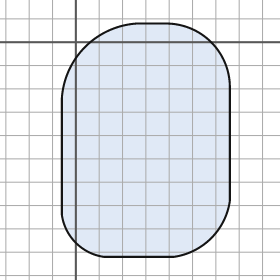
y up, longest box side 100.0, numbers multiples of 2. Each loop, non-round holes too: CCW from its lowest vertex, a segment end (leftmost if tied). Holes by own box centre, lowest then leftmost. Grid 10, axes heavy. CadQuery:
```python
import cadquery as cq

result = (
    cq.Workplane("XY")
    .moveTo(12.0, -92.0)
    .lineTo(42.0, -92.0)
    .threePointArc((58.0, -84.0), (66.0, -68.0))
    .lineTo(66.0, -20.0)
    .threePointArc((58.0, 0.0), (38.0, 8.0))
    .lineTo(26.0, 8.0)
    .threePointArc((4.0, -2.0), (-6.0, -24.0))
    .lineTo(-6.0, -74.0)
    .threePointArc((0.0, -86.0), (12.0, -92.0))
    .close()
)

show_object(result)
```